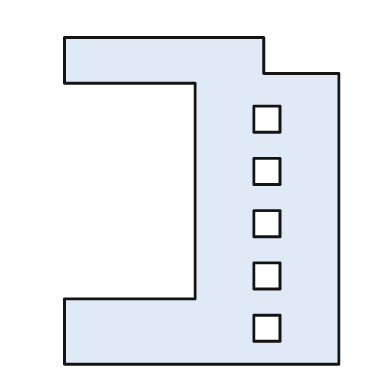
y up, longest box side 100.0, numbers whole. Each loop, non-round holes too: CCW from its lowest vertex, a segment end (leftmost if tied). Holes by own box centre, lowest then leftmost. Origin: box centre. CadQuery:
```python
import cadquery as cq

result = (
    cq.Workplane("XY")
    .moveTo(-42.0, -50.0)
    .lineTo(42.0, -50.0)
    .lineTo(42.0, 39.0)
    .lineTo(19.0, 39.0)
    .lineTo(19.0, 50.0)
    .lineTo(-42.0, 50.0)
    .lineTo(-42.0, 36.0)
    .lineTo(-2.0, 36.0)
    .lineTo(-2.0, -30.0)
    .lineTo(-42.0, -30.0)
    .close()
    .moveTo(16.0, -43.0)
    .lineTo(24.0, -43.0)
    .lineTo(24.0, -35.0)
    .lineTo(16.0, -35.0)
    .close()
    .moveTo(16.0, -27.0)
    .lineTo(24.0, -27.0)
    .lineTo(24.0, -19.0)
    .lineTo(16.0, -19.0)
    .close()
    .moveTo(16.0, -11.0)
    .lineTo(24.0, -11.0)
    .lineTo(24.0, -3.0)
    .lineTo(16.0, -3.0)
    .close()
    .moveTo(16.0, 5.0)
    .lineTo(24.0, 5.0)
    .lineTo(24.0, 13.0)
    .lineTo(16.0, 13.0)
    .close()
    .moveTo(16.0, 21.0)
    .lineTo(24.0, 21.0)
    .lineTo(24.0, 29.0)
    .lineTo(16.0, 29.0)
    .close()
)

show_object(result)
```